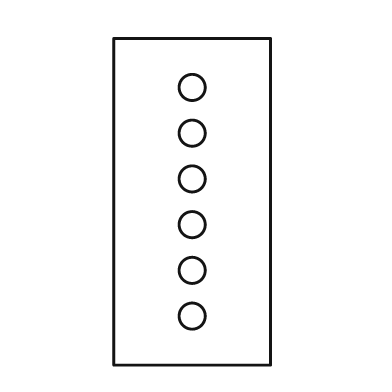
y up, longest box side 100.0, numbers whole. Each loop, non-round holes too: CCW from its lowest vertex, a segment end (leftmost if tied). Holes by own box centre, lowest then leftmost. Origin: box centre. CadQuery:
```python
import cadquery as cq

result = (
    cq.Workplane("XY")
    .moveTo(-24.0, -50.0)
    .lineTo(24.0, -50.0)
    .lineTo(24.0, 50.0)
    .lineTo(-24.0, 50.0)
    .close()
    .moveTo(0.0, -35.0)
    .circle(4.0)
    .moveTo(0.0, -21.0)
    .circle(4.0)
    .moveTo(0.0, -7.0)
    .circle(4.0)
    .moveTo(0.0, 7.0)
    .circle(4.0)
    .moveTo(0.0, 21.0)
    .circle(4.0)
    .moveTo(0.0, 35.0)
    .circle(4.0)
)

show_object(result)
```